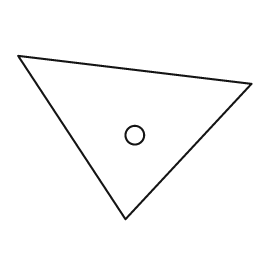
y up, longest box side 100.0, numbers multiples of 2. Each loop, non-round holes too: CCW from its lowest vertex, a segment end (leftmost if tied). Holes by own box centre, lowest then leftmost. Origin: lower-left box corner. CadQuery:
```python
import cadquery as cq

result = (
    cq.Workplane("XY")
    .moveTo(46.0, 0.0)
    .lineTo(100.0, 58.0)
    .lineTo(0.0, 70.0)
    .close()
    .moveTo(50.0, 36.0)
    .circle(4.0)
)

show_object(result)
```